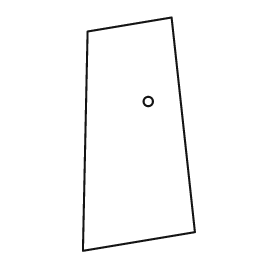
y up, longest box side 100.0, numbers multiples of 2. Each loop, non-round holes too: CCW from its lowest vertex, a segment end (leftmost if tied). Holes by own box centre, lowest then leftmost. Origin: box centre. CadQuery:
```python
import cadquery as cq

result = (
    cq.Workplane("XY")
    .moveTo(-24.0, -50.0)
    .lineTo(24.0, -42.0)
    .lineTo(14.0, 50.0)
    .lineTo(-22.0, 44.0)
    .close()
    .moveTo(4.0, 14.0)
    .circle(2.0)
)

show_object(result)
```